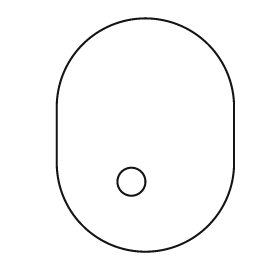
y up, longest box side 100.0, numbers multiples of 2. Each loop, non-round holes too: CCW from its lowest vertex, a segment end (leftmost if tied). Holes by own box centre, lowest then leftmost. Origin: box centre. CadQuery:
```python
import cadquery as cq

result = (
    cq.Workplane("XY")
    .moveTo(-38.0, -12.0)
    .threePointArc((0.0, -50.0), (38.0, -12.0))
    .lineTo(38.0, 12.0)
    .threePointArc((0.0, 50.0), (-38.0, 12.0))
    .close()
    .moveTo(-6.0, -20.0)
    .circle(6.0)
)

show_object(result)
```